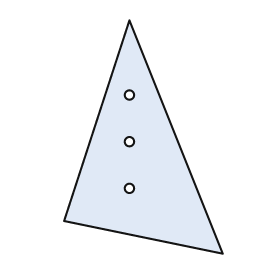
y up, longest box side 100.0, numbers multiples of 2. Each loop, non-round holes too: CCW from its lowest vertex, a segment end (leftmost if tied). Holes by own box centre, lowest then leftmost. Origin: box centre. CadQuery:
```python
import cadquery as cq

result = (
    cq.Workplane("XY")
    .moveTo(34.0, -50.0)
    .lineTo(-6.0, 50.0)
    .lineTo(-34.0, -36.0)
    .close()
    .moveTo(-6.0, -22.0)
    .circle(2.0)
    .moveTo(-6.0, -2.0)
    .circle(2.0)
    .moveTo(-6.0, 18.0)
    .circle(2.0)
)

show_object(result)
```